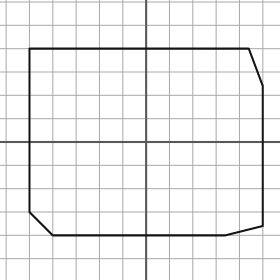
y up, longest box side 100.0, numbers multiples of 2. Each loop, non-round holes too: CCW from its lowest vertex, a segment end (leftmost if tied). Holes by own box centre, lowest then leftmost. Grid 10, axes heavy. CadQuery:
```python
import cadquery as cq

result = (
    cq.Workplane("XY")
    .moveTo(-40.0, -40.0)
    .lineTo(34.0, -40.0)
    .lineTo(50.0, -36.0)
    .lineTo(50.0, 24.0)
    .lineTo(44.0, 40.0)
    .lineTo(-50.0, 40.0)
    .lineTo(-50.0, -30.0)
    .close()
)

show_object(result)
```